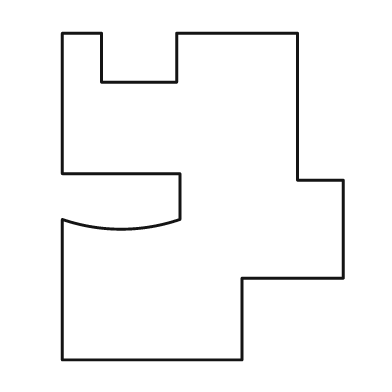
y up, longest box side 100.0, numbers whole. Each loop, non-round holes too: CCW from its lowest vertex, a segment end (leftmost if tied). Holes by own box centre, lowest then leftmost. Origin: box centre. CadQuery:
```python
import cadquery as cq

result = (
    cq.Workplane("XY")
    .moveTo(-43.0, -50.0)
    .lineTo(12.0, -50.0)
    .lineTo(12.0, -25.0)
    .lineTo(43.0, -25.0)
    .lineTo(43.0, 5.0)
    .lineTo(29.0, 5.0)
    .lineTo(29.0, 50.0)
    .lineTo(-8.0, 50.0)
    .lineTo(-8.0, 35.0)
    .lineTo(-31.0, 35.0)
    .lineTo(-31.0, 50.0)
    .lineTo(-43.0, 50.0)
    .lineTo(-43.0, 7.0)
    .lineTo(-7.0, 7.0)
    .lineTo(-7.0, -7.0)
    .threePointArc((-25.0, -10.0), (-43.0, -7.0))
    .close()
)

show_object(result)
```